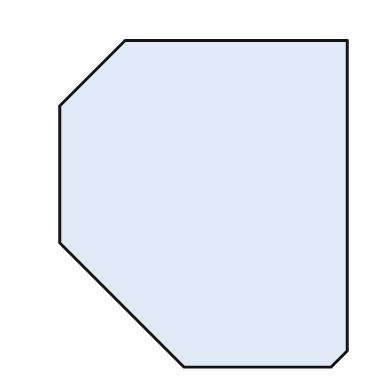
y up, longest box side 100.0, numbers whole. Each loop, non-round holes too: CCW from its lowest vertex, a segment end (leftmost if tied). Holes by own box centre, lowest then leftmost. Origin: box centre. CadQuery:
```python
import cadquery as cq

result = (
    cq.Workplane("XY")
    .moveTo(-6.0, -50.0)
    .lineTo(39.0, -50.0)
    .lineTo(44.0, -45.0)
    .lineTo(44.0, 50.0)
    .lineTo(-24.0, 50.0)
    .lineTo(-44.0, 30.0)
    .lineTo(-44.0, -12.0)
    .close()
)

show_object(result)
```